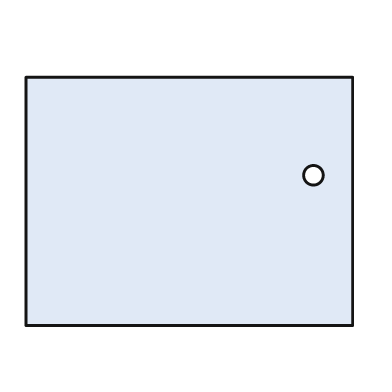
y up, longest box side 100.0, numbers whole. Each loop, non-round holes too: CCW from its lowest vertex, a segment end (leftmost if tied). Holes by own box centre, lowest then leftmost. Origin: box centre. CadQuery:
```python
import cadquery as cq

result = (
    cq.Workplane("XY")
    .moveTo(-50.0, -38.0)
    .lineTo(50.0, -38.0)
    .lineTo(50.0, 38.0)
    .lineTo(-50.0, 38.0)
    .close()
    .moveTo(38.0, 8.0)
    .circle(3.0)
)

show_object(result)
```